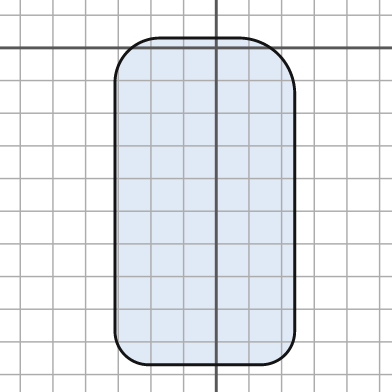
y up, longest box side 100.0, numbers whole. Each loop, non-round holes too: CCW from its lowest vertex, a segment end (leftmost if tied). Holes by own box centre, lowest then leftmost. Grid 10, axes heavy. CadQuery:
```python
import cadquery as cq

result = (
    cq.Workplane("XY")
    .moveTo(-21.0, -97.0)
    .lineTo(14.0, -97.0)
    .threePointArc((21.0, -94.0), (24.0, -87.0))
    .lineTo(24.0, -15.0)
    .threePointArc((19.0, -2.0), (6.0, 3.0))
    .lineTo(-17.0, 3.0)
    .threePointArc((-27.0, -1.0), (-31.0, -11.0))
    .lineTo(-31.0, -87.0)
    .threePointArc((-28.0, -94.0), (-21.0, -97.0))
    .close()
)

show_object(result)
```